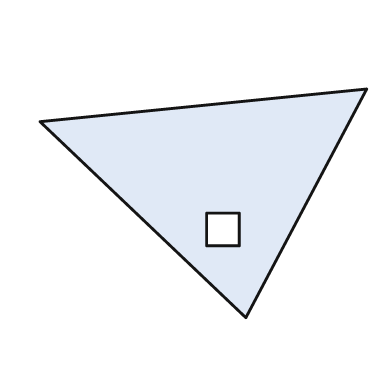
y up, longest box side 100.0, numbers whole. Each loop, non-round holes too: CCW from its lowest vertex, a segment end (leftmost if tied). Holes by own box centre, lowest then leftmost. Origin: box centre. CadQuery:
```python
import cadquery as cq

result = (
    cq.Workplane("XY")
    .moveTo(13.0, -35.0)
    .lineTo(50.0, 35.0)
    .lineTo(-50.0, 25.0)
    .close()
    .moveTo(1.0, -13.0)
    .lineTo(11.0, -13.0)
    .lineTo(11.0, -3.0)
    .lineTo(1.0, -3.0)
    .close()
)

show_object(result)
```